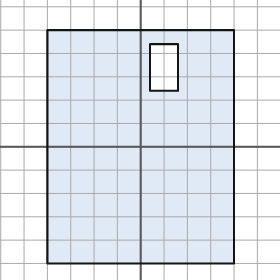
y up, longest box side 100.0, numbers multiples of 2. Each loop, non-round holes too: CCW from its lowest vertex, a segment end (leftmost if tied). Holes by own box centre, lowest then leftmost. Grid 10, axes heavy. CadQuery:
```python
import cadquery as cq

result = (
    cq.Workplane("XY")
    .moveTo(-40.0, -50.0)
    .lineTo(40.0, -50.0)
    .lineTo(40.0, 50.0)
    .lineTo(-40.0, 50.0)
    .close()
    .moveTo(4.0, 24.0)
    .lineTo(16.0, 24.0)
    .lineTo(16.0, 44.0)
    .lineTo(4.0, 44.0)
    .close()
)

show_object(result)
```